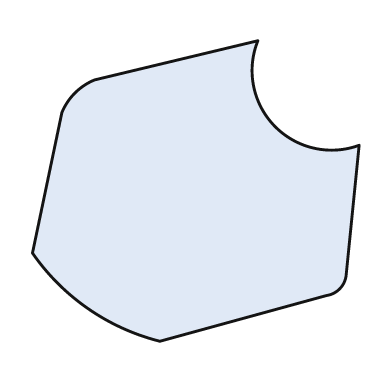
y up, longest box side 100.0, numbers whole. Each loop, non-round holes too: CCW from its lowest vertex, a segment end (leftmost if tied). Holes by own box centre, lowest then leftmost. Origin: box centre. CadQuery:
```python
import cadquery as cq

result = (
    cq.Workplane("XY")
    .moveTo(-11.0, -46.0)
    .lineTo(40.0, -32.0)
    .threePointArc((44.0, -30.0), (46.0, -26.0))
    .lineTo(50.0, 14.0)
    .threePointArc((24.0, 20.0), (19.0, 46.0))
    .lineTo(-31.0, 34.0)
    .threePointArc((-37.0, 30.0), (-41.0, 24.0))
    .lineTo(-50.0, -19.0)
    .threePointArc((-33.0, -36.0), (-11.0, -46.0))
    .close()
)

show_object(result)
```